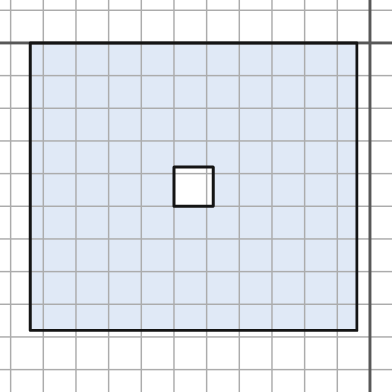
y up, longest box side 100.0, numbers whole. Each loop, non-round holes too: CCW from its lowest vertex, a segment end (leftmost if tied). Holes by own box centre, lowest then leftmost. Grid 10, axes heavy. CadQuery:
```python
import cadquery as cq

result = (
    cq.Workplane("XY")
    .moveTo(-104.0, -88.0)
    .lineTo(-4.0, -88.0)
    .lineTo(-4.0, 0.0)
    .lineTo(-104.0, 0.0)
    .close()
    .moveTo(-60.0, -50.0)
    .lineTo(-48.0, -50.0)
    .lineTo(-48.0, -38.0)
    .lineTo(-60.0, -38.0)
    .close()
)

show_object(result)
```